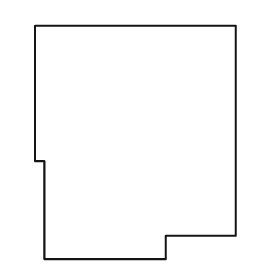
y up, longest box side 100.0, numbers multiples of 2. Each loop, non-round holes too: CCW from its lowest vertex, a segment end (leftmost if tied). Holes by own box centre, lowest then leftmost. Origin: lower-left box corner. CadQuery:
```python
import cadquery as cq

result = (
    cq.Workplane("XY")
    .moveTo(4.0, 0.0)
    .lineTo(56.0, 0.0)
    .lineTo(56.0, 10.0)
    .lineTo(86.0, 10.0)
    .lineTo(86.0, 100.0)
    .lineTo(0.0, 100.0)
    .lineTo(0.0, 42.0)
    .lineTo(4.0, 42.0)
    .close()
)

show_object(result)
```